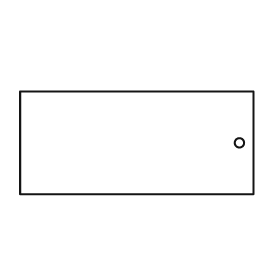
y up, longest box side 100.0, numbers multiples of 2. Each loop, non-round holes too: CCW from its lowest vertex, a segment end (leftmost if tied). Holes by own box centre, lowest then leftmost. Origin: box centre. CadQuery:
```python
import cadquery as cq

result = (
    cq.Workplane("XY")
    .moveTo(-50.0, -22.0)
    .lineTo(50.0, -22.0)
    .lineTo(50.0, 22.0)
    .lineTo(-50.0, 22.0)
    .close()
    .moveTo(44.0, 0.0)
    .circle(2.0)
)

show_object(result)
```